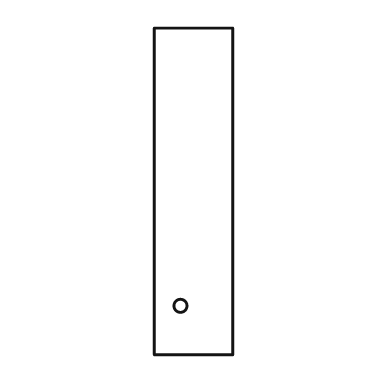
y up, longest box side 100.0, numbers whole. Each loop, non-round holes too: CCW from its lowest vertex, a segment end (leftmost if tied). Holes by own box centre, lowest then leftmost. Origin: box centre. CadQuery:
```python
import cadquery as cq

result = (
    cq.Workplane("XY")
    .moveTo(-12.0, -50.0)
    .lineTo(12.0, -50.0)
    .lineTo(12.0, 50.0)
    .lineTo(-12.0, 50.0)
    .close()
    .moveTo(-4.0, -35.0)
    .circle(2.0)
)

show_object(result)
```